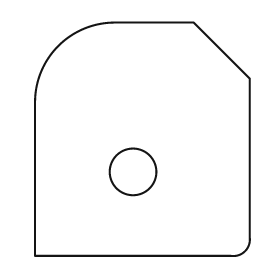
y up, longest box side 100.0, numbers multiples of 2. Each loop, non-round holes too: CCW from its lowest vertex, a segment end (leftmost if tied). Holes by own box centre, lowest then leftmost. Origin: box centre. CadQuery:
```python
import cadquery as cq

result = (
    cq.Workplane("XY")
    .moveTo(-46.0, -50.0)
    .lineTo(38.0, -50.0)
    .threePointArc((44.0, -48.0), (46.0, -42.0))
    .lineTo(46.0, 26.0)
    .lineTo(22.0, 50.0)
    .lineTo(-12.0, 50.0)
    .threePointArc((-36.0, 40.0), (-46.0, 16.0))
    .close()
    .moveTo(-4.0, -14.0)
    .circle(10.0)
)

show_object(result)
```